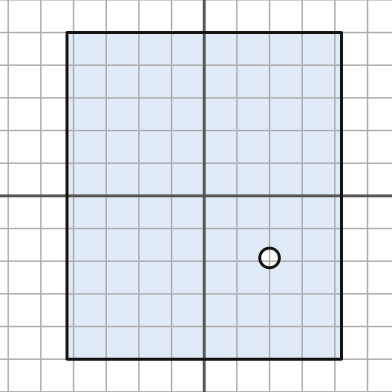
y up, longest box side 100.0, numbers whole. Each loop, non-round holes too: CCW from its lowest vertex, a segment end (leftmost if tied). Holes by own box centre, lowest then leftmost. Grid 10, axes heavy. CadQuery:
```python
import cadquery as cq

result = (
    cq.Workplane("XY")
    .moveTo(-42.0, -50.0)
    .lineTo(42.0, -50.0)
    .lineTo(42.0, 50.0)
    .lineTo(-42.0, 50.0)
    .close()
    .moveTo(20.0, -19.0)
    .circle(3.0)
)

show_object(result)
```